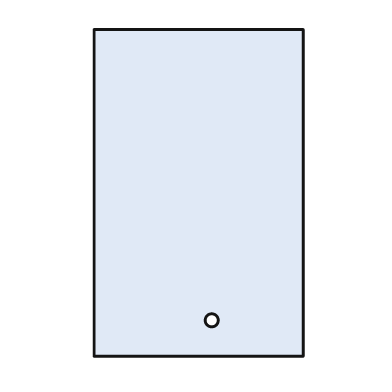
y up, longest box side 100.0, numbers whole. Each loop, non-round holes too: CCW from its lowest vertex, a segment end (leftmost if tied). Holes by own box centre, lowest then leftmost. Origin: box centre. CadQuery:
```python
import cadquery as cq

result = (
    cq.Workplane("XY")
    .moveTo(-32.0, -50.0)
    .lineTo(32.0, -50.0)
    .lineTo(32.0, 50.0)
    .lineTo(-32.0, 50.0)
    .close()
    .moveTo(4.0, -39.0)
    .circle(2.0)
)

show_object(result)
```